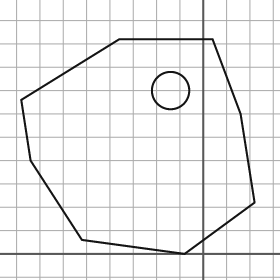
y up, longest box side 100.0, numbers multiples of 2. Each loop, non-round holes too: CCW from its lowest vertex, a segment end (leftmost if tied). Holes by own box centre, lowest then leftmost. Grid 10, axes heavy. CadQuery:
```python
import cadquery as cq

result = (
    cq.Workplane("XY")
    .moveTo(-8.0, 0.0)
    .lineTo(22.0, 22.0)
    .lineTo(16.0, 60.0)
    .lineTo(4.0, 92.0)
    .lineTo(-36.0, 92.0)
    .lineTo(-78.0, 66.0)
    .lineTo(-74.0, 40.0)
    .lineTo(-52.0, 6.0)
    .close()
    .moveTo(-14.0, 70.0)
    .circle(8.0)
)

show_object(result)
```